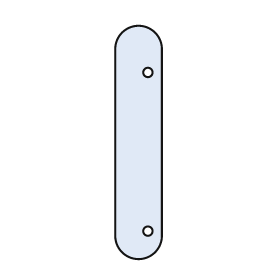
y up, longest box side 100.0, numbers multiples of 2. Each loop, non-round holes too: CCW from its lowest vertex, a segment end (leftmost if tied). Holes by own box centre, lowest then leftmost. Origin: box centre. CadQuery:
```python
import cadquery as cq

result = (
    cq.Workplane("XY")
    .moveTo(-10.0, -40.0)
    .threePointArc((0.0, -50.0), (10.0, -40.0))
    .lineTo(10.0, 40.0)
    .threePointArc((0.0, 50.0), (-10.0, 40.0))
    .close()
    .moveTo(4.0, -38.0)
    .circle(2.0)
    .moveTo(4.0, 30.0)
    .circle(2.0)
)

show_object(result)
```